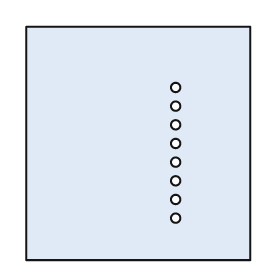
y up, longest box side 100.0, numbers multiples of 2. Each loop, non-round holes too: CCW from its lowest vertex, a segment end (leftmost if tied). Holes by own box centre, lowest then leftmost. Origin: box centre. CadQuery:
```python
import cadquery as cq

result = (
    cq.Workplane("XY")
    .moveTo(-48.0, -50.0)
    .lineTo(48.0, -50.0)
    .lineTo(48.0, 50.0)
    .lineTo(-48.0, 50.0)
    .close()
    .moveTo(16.0, -32.0)
    .circle(2.0)
    .moveTo(16.0, -24.0)
    .circle(2.0)
    .moveTo(16.0, -16.0)
    .circle(2.0)
    .moveTo(16.0, -8.0)
    .circle(2.0)
    .moveTo(16.0, 0.0)
    .circle(2.0)
    .moveTo(16.0, 8.0)
    .circle(2.0)
    .moveTo(16.0, 16.0)
    .circle(2.0)
    .moveTo(16.0, 24.0)
    .circle(2.0)
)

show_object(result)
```